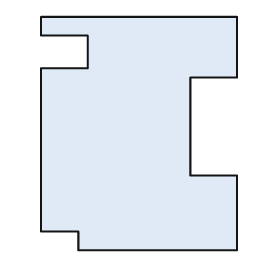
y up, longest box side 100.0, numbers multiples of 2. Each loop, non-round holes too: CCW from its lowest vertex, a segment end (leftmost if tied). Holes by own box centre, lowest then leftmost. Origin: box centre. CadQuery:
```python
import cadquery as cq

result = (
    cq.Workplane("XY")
    .moveTo(-26.0, -50.0)
    .lineTo(42.0, -50.0)
    .lineTo(42.0, -18.0)
    .lineTo(22.0, -18.0)
    .lineTo(22.0, 24.0)
    .lineTo(42.0, 24.0)
    .lineTo(42.0, 50.0)
    .lineTo(-42.0, 50.0)
    .lineTo(-42.0, 42.0)
    .lineTo(-22.0, 42.0)
    .lineTo(-22.0, 28.0)
    .lineTo(-42.0, 28.0)
    .lineTo(-42.0, -42.0)
    .lineTo(-26.0, -42.0)
    .close()
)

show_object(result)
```